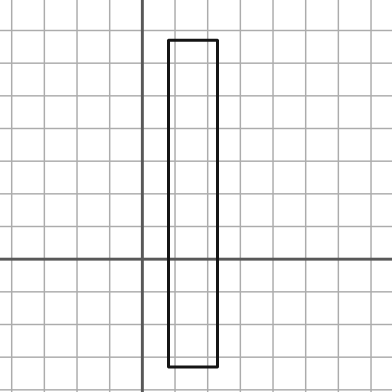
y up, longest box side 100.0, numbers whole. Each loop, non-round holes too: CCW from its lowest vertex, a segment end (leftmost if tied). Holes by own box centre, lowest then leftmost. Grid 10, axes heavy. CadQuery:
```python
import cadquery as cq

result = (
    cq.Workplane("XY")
    .moveTo(8.0, -33.0)
    .lineTo(23.0, -33.0)
    .lineTo(23.0, 67.0)
    .lineTo(8.0, 67.0)
    .close()
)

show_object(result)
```